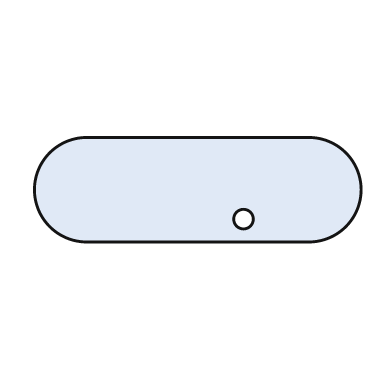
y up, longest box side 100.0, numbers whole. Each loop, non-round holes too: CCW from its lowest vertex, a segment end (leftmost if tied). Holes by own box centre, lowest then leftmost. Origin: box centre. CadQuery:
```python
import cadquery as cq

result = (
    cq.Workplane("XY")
    .moveTo(-34.0, -16.0)
    .lineTo(34.0, -16.0)
    .threePointArc((50.0, 0.0), (34.0, 16.0))
    .lineTo(-34.0, 16.0)
    .threePointArc((-50.0, 0.0), (-34.0, -16.0))
    .close()
    .moveTo(14.0, -9.0)
    .circle(3.0)
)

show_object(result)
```